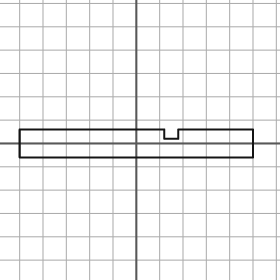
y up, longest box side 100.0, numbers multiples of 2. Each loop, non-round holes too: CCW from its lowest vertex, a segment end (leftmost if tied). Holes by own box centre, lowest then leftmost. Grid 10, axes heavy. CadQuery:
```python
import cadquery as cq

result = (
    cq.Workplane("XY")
    .moveTo(-50.0, -6.0)
    .lineTo(50.0, -6.0)
    .lineTo(50.0, 6.0)
    .lineTo(18.0, 6.0)
    .lineTo(18.0, 2.0)
    .lineTo(12.0, 2.0)
    .lineTo(12.0, 6.0)
    .lineTo(-50.0, 6.0)
    .close()
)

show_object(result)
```